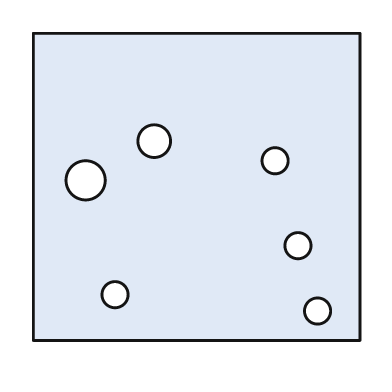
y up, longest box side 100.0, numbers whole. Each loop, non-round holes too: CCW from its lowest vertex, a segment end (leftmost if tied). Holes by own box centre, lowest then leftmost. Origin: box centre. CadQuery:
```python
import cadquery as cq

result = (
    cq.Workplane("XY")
    .moveTo(-50.0, -47.0)
    .lineTo(50.0, -47.0)
    .lineTo(50.0, 47.0)
    .lineTo(-50.0, 47.0)
    .close()
    .moveTo(37.0, -38.0)
    .circle(4.0)
    .moveTo(-25.0, -33.0)
    .circle(4.0)
    .moveTo(31.0, -18.0)
    .circle(4.0)
    .moveTo(-34.0, 2.0)
    .circle(6.0)
    .moveTo(24.0, 8.0)
    .circle(4.0)
    .moveTo(-13.0, 14.0)
    .circle(5.0)
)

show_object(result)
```